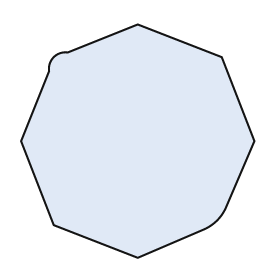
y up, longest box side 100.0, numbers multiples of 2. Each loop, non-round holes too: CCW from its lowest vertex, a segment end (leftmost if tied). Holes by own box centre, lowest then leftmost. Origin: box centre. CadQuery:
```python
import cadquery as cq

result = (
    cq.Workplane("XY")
    .moveTo(0.0, -50.0)
    .lineTo(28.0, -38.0)
    .threePointArc((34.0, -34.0), (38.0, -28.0))
    .lineTo(50.0, 0.0)
    .lineTo(36.0, 36.0)
    .lineTo(0.0, 50.0)
    .lineTo(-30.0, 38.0)
    .threePointArc((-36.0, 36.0), (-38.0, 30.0))
    .lineTo(-50.0, 0.0)
    .lineTo(-36.0, -36.0)
    .close()
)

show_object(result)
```